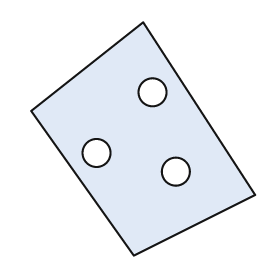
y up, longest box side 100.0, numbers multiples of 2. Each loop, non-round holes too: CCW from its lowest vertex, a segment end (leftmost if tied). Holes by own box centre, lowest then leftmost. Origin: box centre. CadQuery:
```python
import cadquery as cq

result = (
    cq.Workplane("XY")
    .moveTo(-4.0, -50.0)
    .lineTo(48.0, -24.0)
    .lineTo(0.0, 50.0)
    .lineTo(-48.0, 12.0)
    .close()
    .moveTo(14.0, -14.0)
    .circle(6.0)
    .moveTo(-20.0, -6.0)
    .circle(6.0)
    .moveTo(4.0, 20.0)
    .circle(6.0)
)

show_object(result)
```